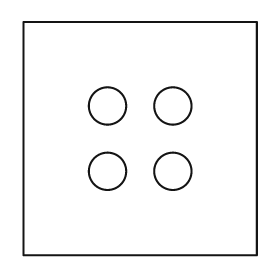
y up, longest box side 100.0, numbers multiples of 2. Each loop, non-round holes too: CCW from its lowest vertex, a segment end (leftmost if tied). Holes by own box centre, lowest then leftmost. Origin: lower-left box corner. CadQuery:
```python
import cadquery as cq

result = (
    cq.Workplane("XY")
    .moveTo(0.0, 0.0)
    .lineTo(100.0, 0.0)
    .lineTo(100.0, 100.0)
    .lineTo(0.0, 100.0)
    .close()
    .moveTo(36.0, 36.0)
    .circle(8.0)
    .moveTo(64.0, 36.0)
    .circle(8.0)
    .moveTo(36.0, 64.0)
    .circle(8.0)
    .moveTo(64.0, 64.0)
    .circle(8.0)
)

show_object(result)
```